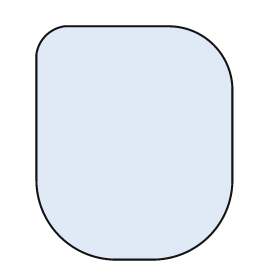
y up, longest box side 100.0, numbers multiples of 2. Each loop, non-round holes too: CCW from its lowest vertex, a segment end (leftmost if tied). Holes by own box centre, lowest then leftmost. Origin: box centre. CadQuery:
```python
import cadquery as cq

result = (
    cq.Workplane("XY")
    .moveTo(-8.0, -50.0)
    .lineTo(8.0, -50.0)
    .threePointArc((32.0, -40.0), (42.0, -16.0))
    .lineTo(42.0, 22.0)
    .threePointArc((34.0, 42.0), (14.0, 50.0))
    .lineTo(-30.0, 50.0)
    .threePointArc((-38.0, 46.0), (-42.0, 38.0))
    .lineTo(-42.0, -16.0)
    .threePointArc((-32.0, -40.0), (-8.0, -50.0))
    .close()
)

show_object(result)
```